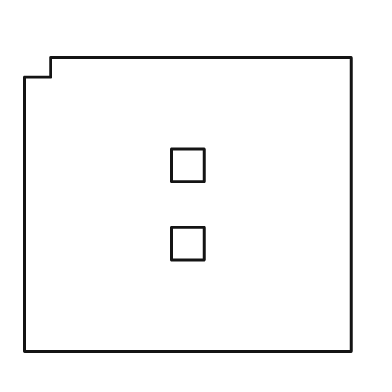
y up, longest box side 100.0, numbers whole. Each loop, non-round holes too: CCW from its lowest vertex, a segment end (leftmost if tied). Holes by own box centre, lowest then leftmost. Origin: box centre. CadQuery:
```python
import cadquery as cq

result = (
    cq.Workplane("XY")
    .moveTo(-50.0, -45.0)
    .lineTo(50.0, -45.0)
    .lineTo(50.0, 45.0)
    .lineTo(-42.0, 45.0)
    .lineTo(-42.0, 39.0)
    .lineTo(-50.0, 39.0)
    .close()
    .moveTo(-5.0, -17.0)
    .lineTo(5.0, -17.0)
    .lineTo(5.0, -7.0)
    .lineTo(-5.0, -7.0)
    .close()
    .moveTo(-5.0, 7.0)
    .lineTo(5.0, 7.0)
    .lineTo(5.0, 17.0)
    .lineTo(-5.0, 17.0)
    .close()
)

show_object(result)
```